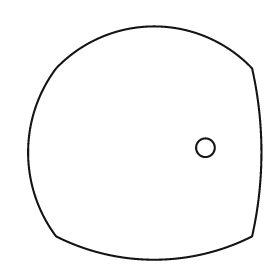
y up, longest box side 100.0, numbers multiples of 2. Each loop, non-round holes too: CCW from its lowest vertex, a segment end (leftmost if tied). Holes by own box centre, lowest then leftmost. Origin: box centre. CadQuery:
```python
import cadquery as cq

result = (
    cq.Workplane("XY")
    .moveTo(-38.0, -40.0)
    .threePointArc((4.0, -50.0), (46.0, -40.0))
    .threePointArc((50.0, -4.0), (46.0, 32.0))
    .threePointArc((4.0, 50.0), (-38.0, 32.0))
    .threePointArc((-50.0, -4.0), (-38.0, -40.0))
    .close()
    .moveTo(26.0, -2.0)
    .circle(4.0)
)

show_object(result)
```